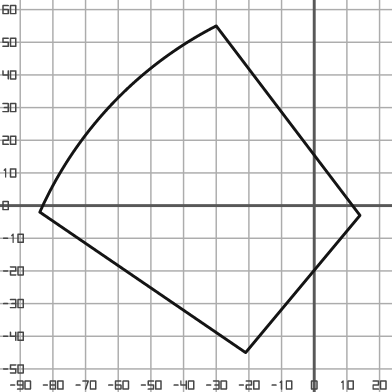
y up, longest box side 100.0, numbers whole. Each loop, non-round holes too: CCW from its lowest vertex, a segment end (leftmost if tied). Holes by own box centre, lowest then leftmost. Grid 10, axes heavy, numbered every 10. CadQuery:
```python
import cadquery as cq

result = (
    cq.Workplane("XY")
    .moveTo(-21.0, -45.0)
    .lineTo(14.0, -3.0)
    .lineTo(-30.0, 55.0)
    .threePointArc((-62.0, 31.0), (-84.0, -2.0))
    .close()
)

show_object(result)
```